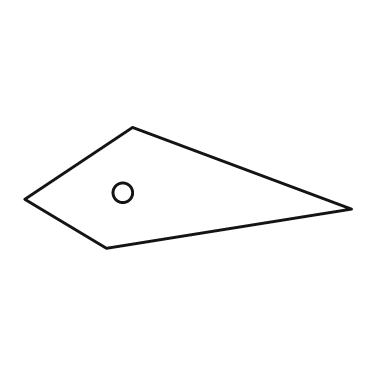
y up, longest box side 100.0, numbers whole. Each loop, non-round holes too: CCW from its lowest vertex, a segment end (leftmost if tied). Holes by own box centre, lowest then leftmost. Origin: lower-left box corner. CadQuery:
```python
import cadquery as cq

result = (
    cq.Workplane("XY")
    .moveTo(25.0, 0.0)
    .lineTo(100.0, 12.0)
    .lineTo(33.0, 37.0)
    .lineTo(0.0, 15.0)
    .close()
    .moveTo(30.0, 17.0)
    .circle(3.0)
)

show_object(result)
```